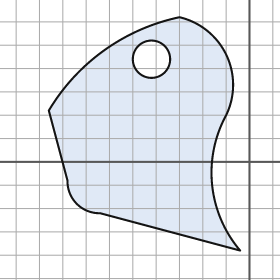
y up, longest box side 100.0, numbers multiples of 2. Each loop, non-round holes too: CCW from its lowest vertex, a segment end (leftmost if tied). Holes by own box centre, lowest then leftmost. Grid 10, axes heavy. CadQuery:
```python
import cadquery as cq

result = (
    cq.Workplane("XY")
    .moveTo(-4.0, -38.0)
    .threePointArc((-16.0, -10.0), (-10.0, 20.0))
    .threePointArc((-10.0, 46.0), (-30.0, 62.0))
    .threePointArc((-62.0, 48.0), (-86.0, 22.0))
    .lineTo(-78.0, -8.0)
    .threePointArc((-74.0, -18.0), (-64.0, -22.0))
    .close()
    .moveTo(-42.0, 44.0)
    .circle(8.0)
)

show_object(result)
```